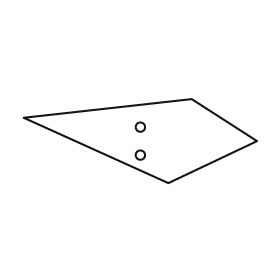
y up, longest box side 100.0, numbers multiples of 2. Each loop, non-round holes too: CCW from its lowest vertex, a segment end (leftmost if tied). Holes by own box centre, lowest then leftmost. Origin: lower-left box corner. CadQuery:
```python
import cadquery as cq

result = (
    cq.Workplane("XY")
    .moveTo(62.0, 0.0)
    .lineTo(100.0, 18.0)
    .lineTo(72.0, 36.0)
    .lineTo(0.0, 28.0)
    .close()
    .moveTo(50.0, 12.0)
    .circle(2.0)
    .moveTo(50.0, 24.0)
    .circle(2.0)
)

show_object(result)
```